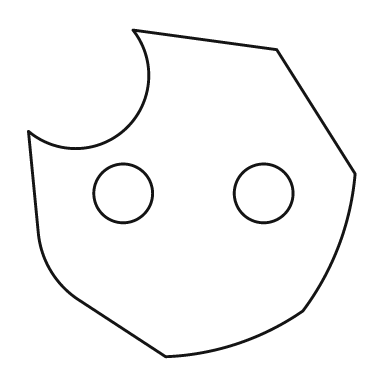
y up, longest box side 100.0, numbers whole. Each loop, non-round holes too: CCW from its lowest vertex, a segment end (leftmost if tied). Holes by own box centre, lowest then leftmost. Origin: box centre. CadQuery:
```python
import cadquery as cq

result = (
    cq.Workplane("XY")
    .moveTo(-8.0, -50.0)
    .threePointArc((14.0, -46.0), (34.0, -36.0))
    .threePointArc((45.0, -16.0), (50.0, 6.0))
    .lineTo(26.0, 44.0)
    .lineTo(-18.0, 50.0)
    .threePointArc((-20.0, 20.0), (-50.0, 19.0))
    .lineTo(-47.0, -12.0)
    .threePointArc((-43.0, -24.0), (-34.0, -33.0))
    .close()
    .moveTo(-21.0, 0.0)
    .circle(9.0)
    .moveTo(22.0, 0.0)
    .circle(9.0)
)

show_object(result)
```